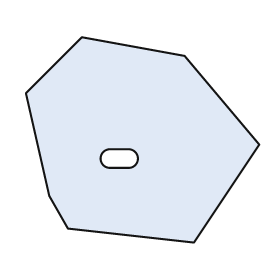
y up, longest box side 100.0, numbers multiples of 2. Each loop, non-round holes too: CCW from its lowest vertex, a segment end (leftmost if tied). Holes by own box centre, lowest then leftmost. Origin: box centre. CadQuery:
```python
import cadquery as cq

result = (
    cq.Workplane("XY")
    .moveTo(22.0, -44.0)
    .lineTo(50.0, -2.0)
    .lineTo(18.0, 36.0)
    .lineTo(-26.0, 44.0)
    .lineTo(-50.0, 20.0)
    .lineTo(-40.0, -24.0)
    .lineTo(-32.0, -38.0)
    .close()
    .moveTo(-14.0, -12.0)
    .lineTo(-6.0, -12.0)
    .threePointArc((-2.0, -8.0), (-6.0, -4.0))
    .lineTo(-14.0, -4.0)
    .threePointArc((-18.0, -8.0), (-14.0, -12.0))
    .close()
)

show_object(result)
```